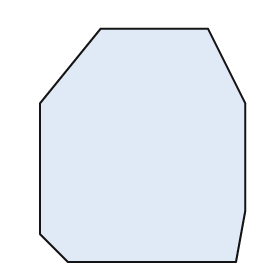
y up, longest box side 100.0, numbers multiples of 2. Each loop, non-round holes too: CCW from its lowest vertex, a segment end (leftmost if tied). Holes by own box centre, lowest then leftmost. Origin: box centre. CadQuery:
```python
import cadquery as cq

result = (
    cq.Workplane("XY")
    .moveTo(-32.0, -50.0)
    .lineTo(40.0, -50.0)
    .lineTo(44.0, -28.0)
    .lineTo(44.0, 18.0)
    .lineTo(28.0, 50.0)
    .lineTo(-18.0, 50.0)
    .lineTo(-44.0, 18.0)
    .lineTo(-44.0, -38.0)
    .close()
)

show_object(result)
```